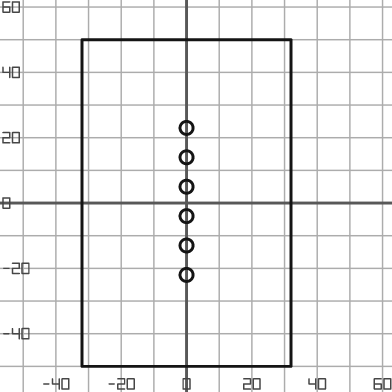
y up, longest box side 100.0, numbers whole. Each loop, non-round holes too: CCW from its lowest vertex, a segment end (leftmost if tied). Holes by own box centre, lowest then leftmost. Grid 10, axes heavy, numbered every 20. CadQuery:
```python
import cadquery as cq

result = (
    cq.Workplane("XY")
    .moveTo(-32.0, -50.0)
    .lineTo(32.0, -50.0)
    .lineTo(32.0, 50.0)
    .lineTo(-32.0, 50.0)
    .close()
    .moveTo(0.0, -22.0)
    .circle(2.0)
    .moveTo(0.0, -13.0)
    .circle(2.0)
    .moveTo(0.0, -4.0)
    .circle(2.0)
    .moveTo(0.0, 5.0)
    .circle(2.0)
    .moveTo(0.0, 14.0)
    .circle(2.0)
    .moveTo(0.0, 23.0)
    .circle(2.0)
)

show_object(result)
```